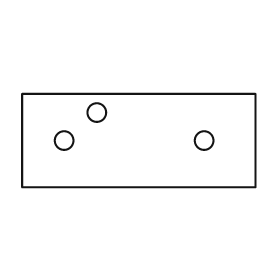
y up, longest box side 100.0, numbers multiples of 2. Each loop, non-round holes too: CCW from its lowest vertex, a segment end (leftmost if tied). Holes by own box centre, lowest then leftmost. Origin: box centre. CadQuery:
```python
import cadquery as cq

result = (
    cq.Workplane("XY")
    .moveTo(-50.0, -20.0)
    .lineTo(50.0, -20.0)
    .lineTo(50.0, 20.0)
    .lineTo(-50.0, 20.0)
    .close()
    .moveTo(-32.0, 0.0)
    .circle(4.0)
    .moveTo(28.0, 0.0)
    .circle(4.0)
    .moveTo(-18.0, 12.0)
    .circle(4.0)
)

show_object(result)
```